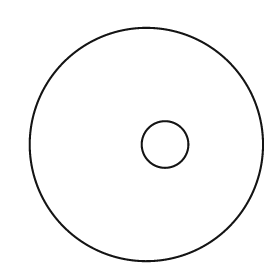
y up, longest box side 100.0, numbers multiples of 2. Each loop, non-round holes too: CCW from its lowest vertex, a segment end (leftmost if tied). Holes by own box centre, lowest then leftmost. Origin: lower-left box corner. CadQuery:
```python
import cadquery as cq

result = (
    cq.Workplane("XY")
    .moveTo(50.0, 50.0)
    .circle(50.0)
    .moveTo(58.0, 50.0)
    .circle(10.0)
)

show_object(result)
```